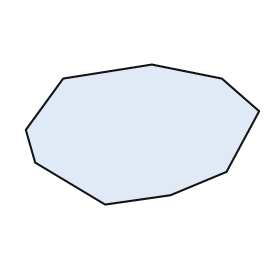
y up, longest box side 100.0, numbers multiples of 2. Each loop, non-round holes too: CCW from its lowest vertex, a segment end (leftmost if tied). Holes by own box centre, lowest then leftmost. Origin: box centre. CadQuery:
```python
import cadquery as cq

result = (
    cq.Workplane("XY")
    .moveTo(-16.0, -30.0)
    .lineTo(12.0, -26.0)
    .lineTo(36.0, -16.0)
    .lineTo(50.0, 10.0)
    .lineTo(34.0, 24.0)
    .lineTo(4.0, 30.0)
    .lineTo(-34.0, 24.0)
    .lineTo(-50.0, 2.0)
    .lineTo(-46.0, -12.0)
    .close()
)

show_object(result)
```